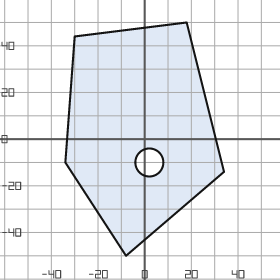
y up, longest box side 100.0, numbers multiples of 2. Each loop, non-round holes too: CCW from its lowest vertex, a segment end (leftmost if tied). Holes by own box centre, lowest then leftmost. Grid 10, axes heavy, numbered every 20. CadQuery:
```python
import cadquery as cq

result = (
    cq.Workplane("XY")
    .moveTo(-8.0, -50.0)
    .lineTo(34.0, -14.0)
    .lineTo(18.0, 50.0)
    .lineTo(-30.0, 44.0)
    .lineTo(-34.0, -10.0)
    .close()
    .moveTo(2.0, -10.0)
    .circle(6.0)
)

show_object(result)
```